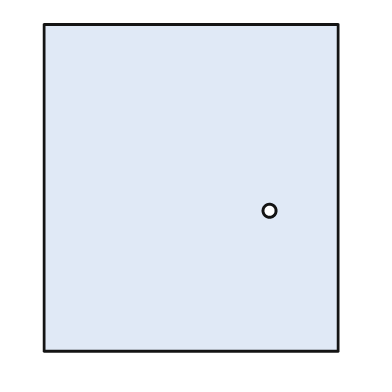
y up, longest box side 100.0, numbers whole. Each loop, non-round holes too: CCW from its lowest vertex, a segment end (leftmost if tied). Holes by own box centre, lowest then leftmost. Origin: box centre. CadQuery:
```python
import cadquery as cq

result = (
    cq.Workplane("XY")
    .moveTo(-45.0, -50.0)
    .lineTo(45.0, -50.0)
    .lineTo(45.0, 50.0)
    .lineTo(-45.0, 50.0)
    .close()
    .moveTo(24.0, -7.0)
    .circle(2.0)
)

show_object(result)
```